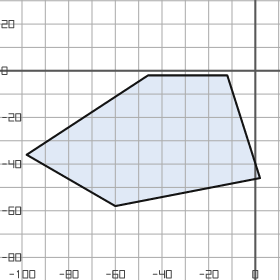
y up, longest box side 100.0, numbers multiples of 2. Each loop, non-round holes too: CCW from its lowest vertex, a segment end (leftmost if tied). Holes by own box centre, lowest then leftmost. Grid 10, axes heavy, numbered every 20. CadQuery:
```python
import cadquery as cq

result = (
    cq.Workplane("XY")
    .moveTo(-60.0, -58.0)
    .lineTo(2.0, -46.0)
    .lineTo(-12.0, -2.0)
    .lineTo(-46.0, -2.0)
    .lineTo(-98.0, -36.0)
    .close()
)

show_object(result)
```